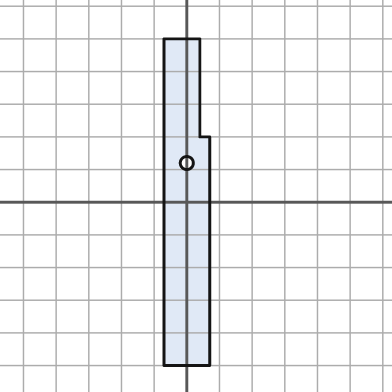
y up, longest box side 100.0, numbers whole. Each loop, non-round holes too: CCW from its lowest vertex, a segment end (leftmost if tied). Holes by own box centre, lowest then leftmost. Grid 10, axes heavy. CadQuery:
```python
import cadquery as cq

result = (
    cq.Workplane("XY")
    .moveTo(-7.0, -50.0)
    .lineTo(7.0, -50.0)
    .lineTo(7.0, 20.0)
    .lineTo(4.0, 20.0)
    .lineTo(4.0, 50.0)
    .lineTo(-7.0, 50.0)
    .close()
    .moveTo(0.0, 12.0)
    .circle(2.0)
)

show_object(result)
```